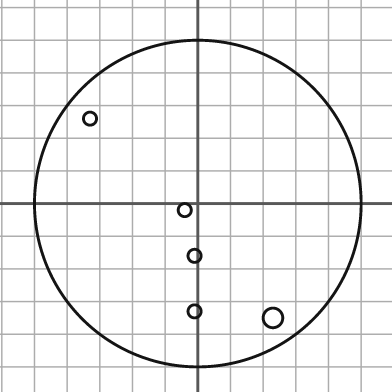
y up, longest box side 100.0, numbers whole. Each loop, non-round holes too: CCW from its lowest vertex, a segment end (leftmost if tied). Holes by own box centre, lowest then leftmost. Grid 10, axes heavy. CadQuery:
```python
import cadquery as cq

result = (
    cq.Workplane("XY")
    .moveTo(0.0, 0.0)
    .circle(50.0)
    .moveTo(23.0, -35.0)
    .circle(3.0)
    .moveTo(-1.0, -33.0)
    .circle(2.0)
    .moveTo(-1.0, -16.0)
    .circle(2.0)
    .moveTo(-4.0, -2.0)
    .circle(2.0)
    .moveTo(-33.0, 26.0)
    .circle(2.0)
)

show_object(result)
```